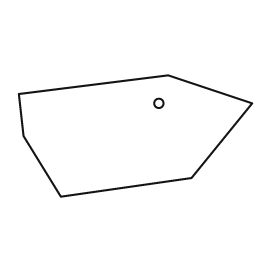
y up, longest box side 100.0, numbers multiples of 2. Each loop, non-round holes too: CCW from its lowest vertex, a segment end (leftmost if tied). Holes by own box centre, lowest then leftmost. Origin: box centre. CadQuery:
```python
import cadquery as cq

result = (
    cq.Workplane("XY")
    .moveTo(-32.0, -26.0)
    .lineTo(24.0, -18.0)
    .lineTo(50.0, 14.0)
    .lineTo(14.0, 26.0)
    .lineTo(-50.0, 18.0)
    .lineTo(-48.0, 0.0)
    .close()
    .moveTo(10.0, 14.0)
    .circle(2.0)
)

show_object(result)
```